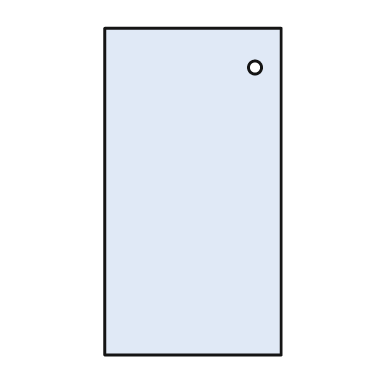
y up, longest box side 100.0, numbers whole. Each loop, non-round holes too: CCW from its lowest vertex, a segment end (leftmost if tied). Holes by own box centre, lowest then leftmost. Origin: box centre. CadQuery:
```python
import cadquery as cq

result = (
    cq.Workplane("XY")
    .moveTo(-27.0, -50.0)
    .lineTo(27.0, -50.0)
    .lineTo(27.0, 50.0)
    .lineTo(-27.0, 50.0)
    .close()
    .moveTo(19.0, 38.0)
    .circle(2.0)
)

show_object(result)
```